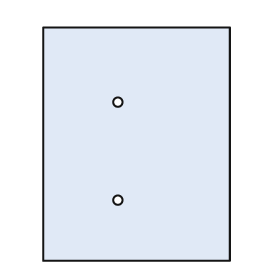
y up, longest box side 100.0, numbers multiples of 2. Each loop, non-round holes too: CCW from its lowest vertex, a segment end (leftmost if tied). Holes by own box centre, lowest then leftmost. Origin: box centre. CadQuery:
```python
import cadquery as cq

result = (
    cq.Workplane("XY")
    .moveTo(-40.0, -50.0)
    .lineTo(40.0, -50.0)
    .lineTo(40.0, 50.0)
    .lineTo(-40.0, 50.0)
    .close()
    .moveTo(-8.0, -24.0)
    .circle(2.0)
    .moveTo(-8.0, 18.0)
    .circle(2.0)
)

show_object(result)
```